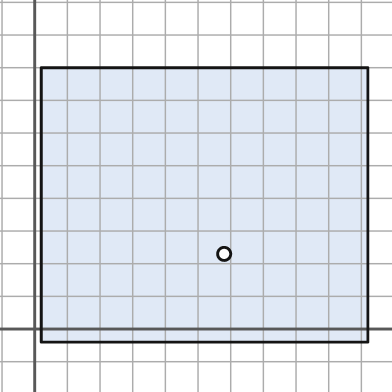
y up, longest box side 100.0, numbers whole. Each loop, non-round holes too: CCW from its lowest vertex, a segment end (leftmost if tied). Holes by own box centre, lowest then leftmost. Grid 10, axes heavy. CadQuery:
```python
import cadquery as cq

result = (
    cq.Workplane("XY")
    .moveTo(2.0, -4.0)
    .lineTo(102.0, -4.0)
    .lineTo(102.0, 80.0)
    .lineTo(2.0, 80.0)
    .close()
    .moveTo(58.0, 23.0)
    .circle(2.0)
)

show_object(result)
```